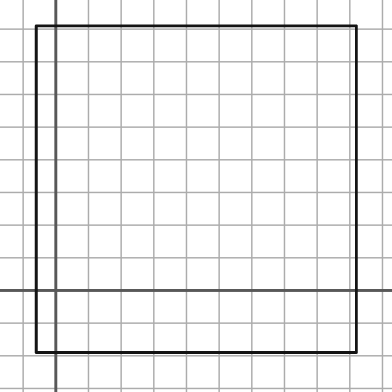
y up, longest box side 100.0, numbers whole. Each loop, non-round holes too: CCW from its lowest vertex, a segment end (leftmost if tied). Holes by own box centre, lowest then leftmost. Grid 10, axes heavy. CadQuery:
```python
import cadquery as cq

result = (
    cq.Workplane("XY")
    .moveTo(-6.0, -19.0)
    .lineTo(92.0, -19.0)
    .lineTo(92.0, 81.0)
    .lineTo(-6.0, 81.0)
    .close()
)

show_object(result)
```